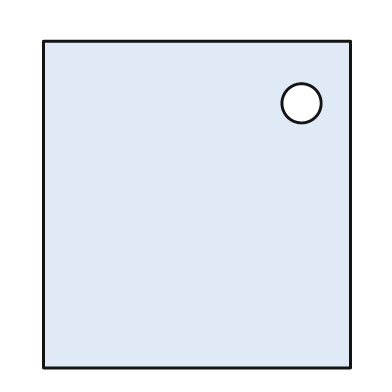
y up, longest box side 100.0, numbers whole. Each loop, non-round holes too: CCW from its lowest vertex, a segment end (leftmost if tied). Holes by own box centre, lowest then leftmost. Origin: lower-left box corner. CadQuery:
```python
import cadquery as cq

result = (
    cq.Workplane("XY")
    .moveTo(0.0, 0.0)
    .lineTo(94.0, 0.0)
    .lineTo(94.0, 100.0)
    .lineTo(0.0, 100.0)
    .close()
    .moveTo(79.0, 81.0)
    .circle(6.0)
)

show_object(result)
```